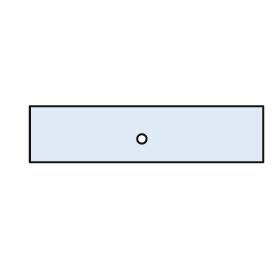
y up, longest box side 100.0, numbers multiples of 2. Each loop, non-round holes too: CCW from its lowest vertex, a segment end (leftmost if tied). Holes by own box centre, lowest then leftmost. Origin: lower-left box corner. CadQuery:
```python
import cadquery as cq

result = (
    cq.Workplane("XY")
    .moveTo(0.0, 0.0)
    .lineTo(100.0, 0.0)
    .lineTo(100.0, 24.0)
    .lineTo(0.0, 24.0)
    .close()
    .moveTo(48.0, 10.0)
    .circle(2.0)
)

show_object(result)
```